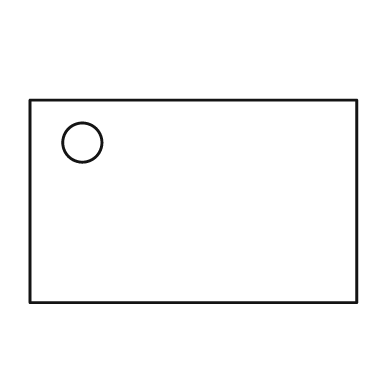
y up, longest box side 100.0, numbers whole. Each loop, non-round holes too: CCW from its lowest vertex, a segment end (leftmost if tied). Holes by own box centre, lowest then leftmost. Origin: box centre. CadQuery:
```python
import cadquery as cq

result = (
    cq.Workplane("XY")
    .moveTo(-50.0, -31.0)
    .lineTo(50.0, -31.0)
    .lineTo(50.0, 31.0)
    .lineTo(-50.0, 31.0)
    .close()
    .moveTo(-34.0, 18.0)
    .circle(6.0)
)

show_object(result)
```